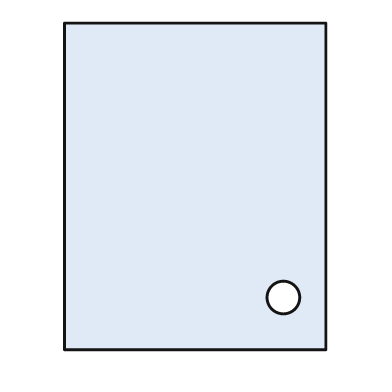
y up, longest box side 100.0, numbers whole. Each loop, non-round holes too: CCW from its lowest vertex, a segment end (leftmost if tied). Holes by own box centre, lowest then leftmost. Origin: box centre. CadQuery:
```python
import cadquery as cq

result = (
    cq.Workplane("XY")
    .moveTo(-40.0, -50.0)
    .lineTo(40.0, -50.0)
    .lineTo(40.0, 50.0)
    .lineTo(-40.0, 50.0)
    .close()
    .moveTo(27.0, -34.0)
    .circle(5.0)
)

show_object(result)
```